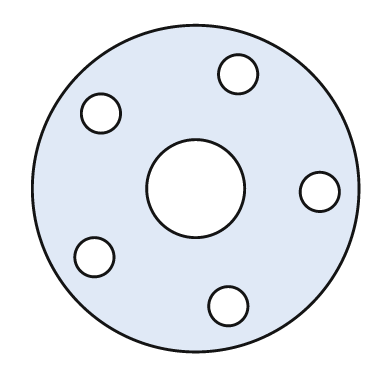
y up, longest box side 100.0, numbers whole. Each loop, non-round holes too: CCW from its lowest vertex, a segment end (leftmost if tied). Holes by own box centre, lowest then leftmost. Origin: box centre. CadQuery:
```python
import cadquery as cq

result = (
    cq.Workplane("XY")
    .moveTo(0.0, 0.0)
    .circle(50.0)
    .moveTo(10.0, -36.0)
    .circle(6.0)
    .moveTo(-31.0, -21.0)
    .circle(6.0)
    .moveTo(38.0, -1.0)
    .circle(6.0)
    .moveTo(0.0, 0.0)
    .circle(15.0)
    .moveTo(-29.0, 23.0)
    .circle(6.0)
    .moveTo(13.0, 35.0)
    .circle(6.0)
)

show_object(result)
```